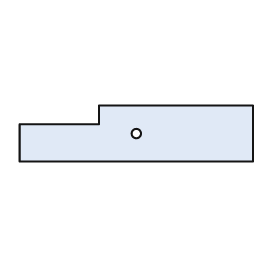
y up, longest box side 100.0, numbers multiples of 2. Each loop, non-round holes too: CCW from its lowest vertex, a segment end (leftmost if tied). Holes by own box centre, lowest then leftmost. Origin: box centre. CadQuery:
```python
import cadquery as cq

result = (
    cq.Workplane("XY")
    .moveTo(-50.0, -12.0)
    .lineTo(50.0, -12.0)
    .lineTo(50.0, 12.0)
    .lineTo(-16.0, 12.0)
    .lineTo(-16.0, 4.0)
    .lineTo(-50.0, 4.0)
    .close()
    .moveTo(0.0, 0.0)
    .circle(2.0)
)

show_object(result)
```